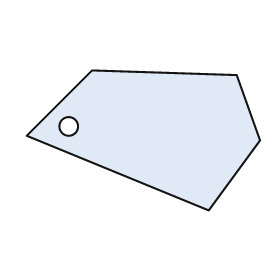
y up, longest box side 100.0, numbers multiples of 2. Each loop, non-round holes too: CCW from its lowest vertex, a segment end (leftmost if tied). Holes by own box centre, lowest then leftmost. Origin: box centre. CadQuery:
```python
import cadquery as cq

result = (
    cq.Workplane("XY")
    .moveTo(28.0, -30.0)
    .lineTo(50.0, 0.0)
    .lineTo(40.0, 28.0)
    .lineTo(-22.0, 30.0)
    .lineTo(-50.0, 2.0)
    .close()
    .moveTo(-32.0, 6.0)
    .circle(4.0)
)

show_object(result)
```